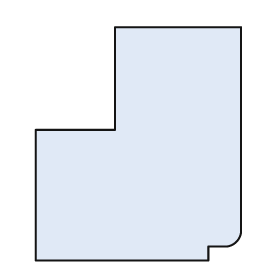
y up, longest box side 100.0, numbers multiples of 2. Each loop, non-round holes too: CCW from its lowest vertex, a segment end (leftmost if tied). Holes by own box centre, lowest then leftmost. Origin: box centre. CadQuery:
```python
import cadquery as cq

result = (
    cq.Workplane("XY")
    .moveTo(-44.0, -50.0)
    .lineTo(30.0, -50.0)
    .lineTo(30.0, -44.0)
    .lineTo(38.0, -44.0)
    .threePointArc((42.0, -42.0), (44.0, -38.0))
    .lineTo(44.0, 50.0)
    .lineTo(-10.0, 50.0)
    .lineTo(-10.0, 6.0)
    .lineTo(-44.0, 6.0)
    .close()
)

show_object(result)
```